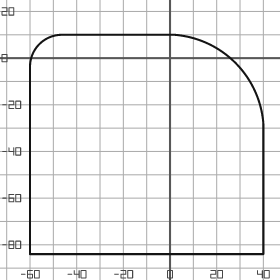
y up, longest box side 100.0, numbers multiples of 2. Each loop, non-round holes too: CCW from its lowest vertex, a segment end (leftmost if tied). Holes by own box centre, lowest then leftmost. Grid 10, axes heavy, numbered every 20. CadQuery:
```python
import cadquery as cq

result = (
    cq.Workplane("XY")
    .moveTo(-60.0, -84.0)
    .lineTo(40.0, -84.0)
    .lineTo(40.0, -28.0)
    .threePointArc((28.0, -2.0), (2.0, 10.0))
    .lineTo(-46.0, 10.0)
    .threePointArc((-56.0, 6.0), (-60.0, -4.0))
    .close()
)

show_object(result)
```